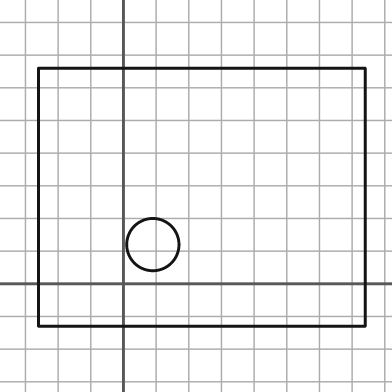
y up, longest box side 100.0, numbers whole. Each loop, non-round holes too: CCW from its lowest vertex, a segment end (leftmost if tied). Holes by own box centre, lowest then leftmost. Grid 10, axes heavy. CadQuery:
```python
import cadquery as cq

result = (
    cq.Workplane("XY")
    .moveTo(-26.0, -13.0)
    .lineTo(74.0, -13.0)
    .lineTo(74.0, 66.0)
    .lineTo(-26.0, 66.0)
    .close()
    .moveTo(9.0, 12.0)
    .circle(8.0)
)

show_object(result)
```